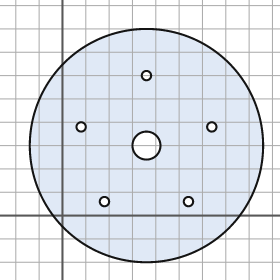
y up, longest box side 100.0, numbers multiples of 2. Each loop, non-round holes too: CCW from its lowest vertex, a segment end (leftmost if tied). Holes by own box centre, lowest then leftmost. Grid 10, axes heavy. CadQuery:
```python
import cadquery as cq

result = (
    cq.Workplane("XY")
    .moveTo(36.0, 30.0)
    .circle(50.0)
    .moveTo(18.0, 6.0)
    .circle(2.0)
    .moveTo(54.0, 6.0)
    .circle(2.0)
    .moveTo(36.0, 30.0)
    .circle(6.0)
    .moveTo(8.0, 38.0)
    .circle(2.0)
    .moveTo(64.0, 38.0)
    .circle(2.0)
    .moveTo(36.0, 60.0)
    .circle(2.0)
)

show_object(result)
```